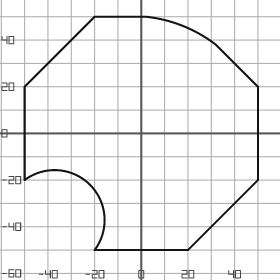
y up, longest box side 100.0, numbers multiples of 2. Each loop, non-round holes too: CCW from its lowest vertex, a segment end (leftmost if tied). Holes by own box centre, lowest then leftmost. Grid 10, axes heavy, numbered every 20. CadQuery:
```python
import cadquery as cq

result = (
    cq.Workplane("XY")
    .moveTo(-20.0, -50.0)
    .lineTo(20.0, -50.0)
    .lineTo(50.0, -20.0)
    .lineTo(50.0, 20.0)
    .lineTo(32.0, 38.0)
    .threePointArc((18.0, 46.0), (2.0, 50.0))
    .lineTo(-20.0, 50.0)
    .lineTo(-50.0, 20.0)
    .lineTo(-50.0, -20.0)
    .threePointArc((-22.0, -22.0), (-20.0, -50.0))
    .close()
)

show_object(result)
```